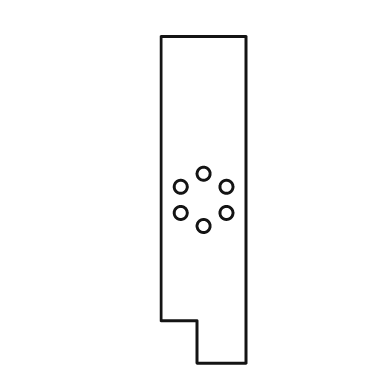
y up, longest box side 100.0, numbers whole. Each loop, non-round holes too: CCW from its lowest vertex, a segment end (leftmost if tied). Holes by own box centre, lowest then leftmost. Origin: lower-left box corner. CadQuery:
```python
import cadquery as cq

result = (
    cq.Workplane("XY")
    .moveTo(11.0, 0.0)
    .lineTo(26.0, 0.0)
    .lineTo(26.0, 100.0)
    .lineTo(0.0, 100.0)
    .lineTo(0.0, 13.0)
    .lineTo(11.0, 13.0)
    .close()
    .moveTo(13.0, 42.0)
    .circle(2.0)
    .moveTo(6.0, 46.0)
    .circle(2.0)
    .moveTo(20.0, 46.0)
    .circle(2.0)
    .moveTo(6.0, 54.0)
    .circle(2.0)
    .moveTo(20.0, 54.0)
    .circle(2.0)
    .moveTo(13.0, 58.0)
    .circle(2.0)
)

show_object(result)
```